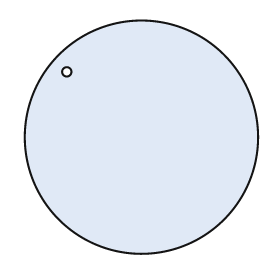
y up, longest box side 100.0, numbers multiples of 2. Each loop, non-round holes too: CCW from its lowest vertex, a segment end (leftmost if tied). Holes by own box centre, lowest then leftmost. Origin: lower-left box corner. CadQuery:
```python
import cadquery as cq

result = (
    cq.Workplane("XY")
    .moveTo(50.0, 50.0)
    .circle(50.0)
    .moveTo(18.0, 78.0)
    .circle(2.0)
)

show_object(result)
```